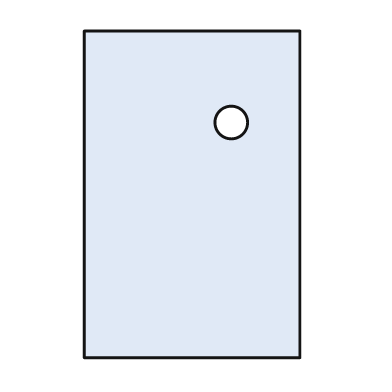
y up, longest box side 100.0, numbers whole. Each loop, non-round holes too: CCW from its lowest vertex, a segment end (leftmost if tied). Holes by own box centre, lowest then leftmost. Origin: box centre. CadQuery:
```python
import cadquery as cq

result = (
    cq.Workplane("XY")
    .moveTo(-33.0, -50.0)
    .lineTo(33.0, -50.0)
    .lineTo(33.0, 50.0)
    .lineTo(-33.0, 50.0)
    .close()
    .moveTo(12.0, 22.0)
    .circle(5.0)
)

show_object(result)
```